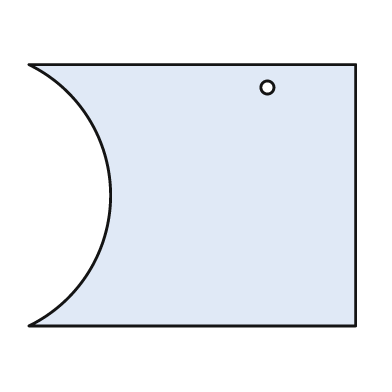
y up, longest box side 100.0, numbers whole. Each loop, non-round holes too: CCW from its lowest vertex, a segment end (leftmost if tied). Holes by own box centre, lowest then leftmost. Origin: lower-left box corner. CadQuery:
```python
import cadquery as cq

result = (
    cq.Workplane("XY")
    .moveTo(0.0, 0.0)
    .lineTo(100.0, 0.0)
    .lineTo(100.0, 80.0)
    .lineTo(0.0, 80.0)
    .threePointArc((25.0, 40.0), (0.0, 0.0))
    .close()
    .moveTo(73.0, 73.0)
    .circle(2.0)
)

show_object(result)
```